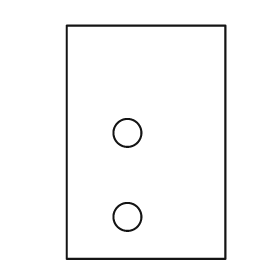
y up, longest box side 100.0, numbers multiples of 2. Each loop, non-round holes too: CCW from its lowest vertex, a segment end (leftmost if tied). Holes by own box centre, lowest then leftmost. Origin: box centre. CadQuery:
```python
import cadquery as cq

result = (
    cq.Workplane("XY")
    .moveTo(-34.0, -50.0)
    .lineTo(34.0, -50.0)
    .lineTo(34.0, 50.0)
    .lineTo(-34.0, 50.0)
    .close()
    .moveTo(-8.0, -32.0)
    .circle(6.0)
    .moveTo(-8.0, 4.0)
    .circle(6.0)
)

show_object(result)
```